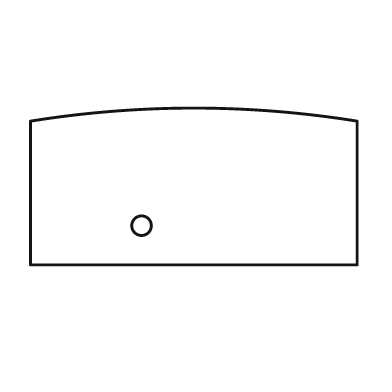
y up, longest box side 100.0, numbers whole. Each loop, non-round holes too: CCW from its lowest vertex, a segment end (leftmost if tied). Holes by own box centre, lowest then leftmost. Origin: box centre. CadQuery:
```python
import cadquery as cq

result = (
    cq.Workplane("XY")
    .moveTo(-50.0, -24.0)
    .lineTo(50.0, -24.0)
    .lineTo(50.0, 20.0)
    .threePointArc((0.0, 24.0), (-50.0, 20.0))
    .close()
    .moveTo(-16.0, -12.0)
    .circle(3.0)
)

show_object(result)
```